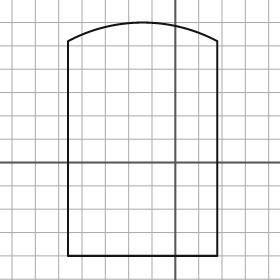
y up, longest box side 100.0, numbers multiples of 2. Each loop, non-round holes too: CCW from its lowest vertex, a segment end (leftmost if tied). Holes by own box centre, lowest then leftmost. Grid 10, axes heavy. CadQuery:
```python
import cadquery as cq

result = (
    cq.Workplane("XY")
    .moveTo(-46.0, -40.0)
    .lineTo(18.0, -40.0)
    .lineTo(18.0, 52.0)
    .threePointArc((-14.0, 60.0), (-46.0, 52.0))
    .close()
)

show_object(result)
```